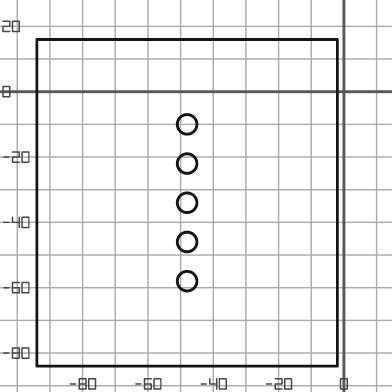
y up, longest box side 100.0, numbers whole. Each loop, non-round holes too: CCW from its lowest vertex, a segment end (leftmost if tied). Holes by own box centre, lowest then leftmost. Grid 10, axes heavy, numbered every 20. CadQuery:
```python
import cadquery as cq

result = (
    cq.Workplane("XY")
    .moveTo(-94.0, -84.0)
    .lineTo(-2.0, -84.0)
    .lineTo(-2.0, 16.0)
    .lineTo(-94.0, 16.0)
    .close()
    .moveTo(-48.0, -58.0)
    .circle(3.0)
    .moveTo(-48.0, -46.0)
    .circle(3.0)
    .moveTo(-48.0, -34.0)
    .circle(3.0)
    .moveTo(-48.0, -22.0)
    .circle(3.0)
    .moveTo(-48.0, -10.0)
    .circle(3.0)
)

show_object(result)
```